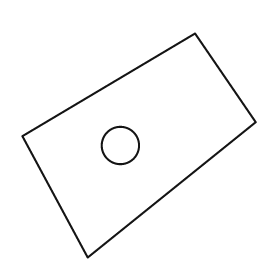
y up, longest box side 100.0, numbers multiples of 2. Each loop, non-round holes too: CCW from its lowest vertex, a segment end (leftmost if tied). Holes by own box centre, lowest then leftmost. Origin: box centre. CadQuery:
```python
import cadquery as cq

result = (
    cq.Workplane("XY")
    .moveTo(-22.0, -48.0)
    .lineTo(50.0, 10.0)
    .lineTo(24.0, 48.0)
    .lineTo(-50.0, 4.0)
    .close()
    .moveTo(-8.0, 0.0)
    .circle(8.0)
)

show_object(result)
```